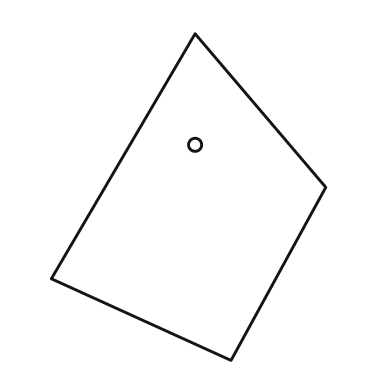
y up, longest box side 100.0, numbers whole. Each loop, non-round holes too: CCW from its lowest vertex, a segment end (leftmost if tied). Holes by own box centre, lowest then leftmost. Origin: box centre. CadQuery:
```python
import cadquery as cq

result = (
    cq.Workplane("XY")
    .moveTo(13.0, -50.0)
    .lineTo(42.0, 3.0)
    .lineTo(2.0, 50.0)
    .lineTo(-42.0, -25.0)
    .close()
    .moveTo(2.0, 16.0)
    .circle(2.0)
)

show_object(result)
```